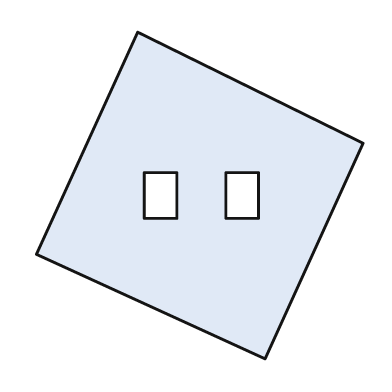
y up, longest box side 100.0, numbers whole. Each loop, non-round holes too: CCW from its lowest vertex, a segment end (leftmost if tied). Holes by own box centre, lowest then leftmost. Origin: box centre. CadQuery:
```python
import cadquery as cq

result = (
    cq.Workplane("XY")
    .moveTo(20.0, -50.0)
    .lineTo(50.0, 16.0)
    .lineTo(-19.0, 50.0)
    .lineTo(-50.0, -18.0)
    .close()
    .moveTo(-17.0, -7.0)
    .lineTo(-7.0, -7.0)
    .lineTo(-7.0, 7.0)
    .lineTo(-17.0, 7.0)
    .close()
    .moveTo(8.0, -7.0)
    .lineTo(18.0, -7.0)
    .lineTo(18.0, 7.0)
    .lineTo(8.0, 7.0)
    .close()
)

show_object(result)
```